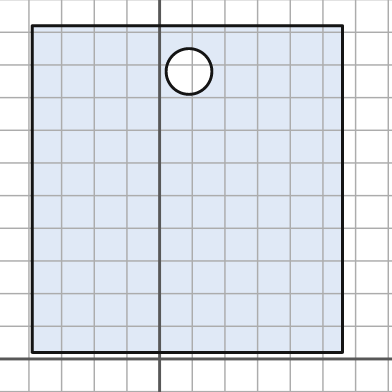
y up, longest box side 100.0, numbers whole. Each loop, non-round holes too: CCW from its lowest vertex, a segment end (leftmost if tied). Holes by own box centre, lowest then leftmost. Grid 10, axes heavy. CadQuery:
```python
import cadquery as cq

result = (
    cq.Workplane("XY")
    .moveTo(-39.0, 2.0)
    .lineTo(56.0, 2.0)
    .lineTo(56.0, 102.0)
    .lineTo(-39.0, 102.0)
    .close()
    .moveTo(9.0, 88.0)
    .circle(7.0)
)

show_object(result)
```